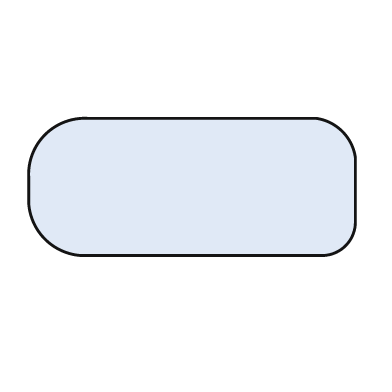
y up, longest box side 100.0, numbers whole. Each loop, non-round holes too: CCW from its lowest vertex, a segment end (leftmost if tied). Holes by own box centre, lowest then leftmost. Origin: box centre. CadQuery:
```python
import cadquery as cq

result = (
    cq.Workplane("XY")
    .moveTo(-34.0, -21.0)
    .lineTo(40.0, -21.0)
    .threePointArc((47.0, -18.0), (50.0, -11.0))
    .lineTo(50.0, 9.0)
    .threePointArc((46.0, 17.0), (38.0, 21.0))
    .lineTo(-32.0, 21.0)
    .threePointArc((-45.0, 16.0), (-50.0, 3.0))
    .lineTo(-50.0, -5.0)
    .threePointArc((-45.0, -16.0), (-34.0, -21.0))
    .close()
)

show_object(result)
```